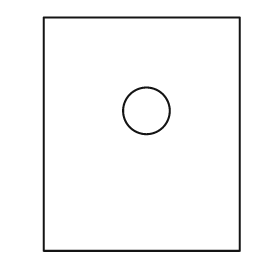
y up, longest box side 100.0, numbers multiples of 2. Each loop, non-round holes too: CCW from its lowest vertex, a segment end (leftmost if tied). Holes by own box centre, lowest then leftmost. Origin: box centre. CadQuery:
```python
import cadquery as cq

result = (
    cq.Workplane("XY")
    .moveTo(-42.0, -50.0)
    .lineTo(42.0, -50.0)
    .lineTo(42.0, 50.0)
    .lineTo(-42.0, 50.0)
    .close()
    .moveTo(2.0, 10.0)
    .circle(10.0)
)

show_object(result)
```